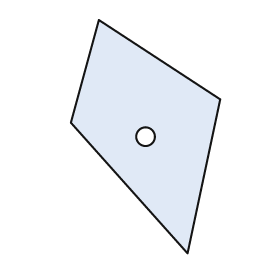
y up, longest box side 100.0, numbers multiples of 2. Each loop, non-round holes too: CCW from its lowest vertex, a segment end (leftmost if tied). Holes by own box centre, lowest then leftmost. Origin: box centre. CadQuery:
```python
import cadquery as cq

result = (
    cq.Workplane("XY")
    .moveTo(18.0, -50.0)
    .lineTo(32.0, 16.0)
    .lineTo(-20.0, 50.0)
    .lineTo(-32.0, 6.0)
    .close()
    .moveTo(0.0, 0.0)
    .circle(4.0)
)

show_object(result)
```